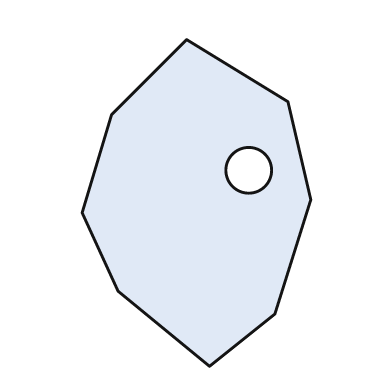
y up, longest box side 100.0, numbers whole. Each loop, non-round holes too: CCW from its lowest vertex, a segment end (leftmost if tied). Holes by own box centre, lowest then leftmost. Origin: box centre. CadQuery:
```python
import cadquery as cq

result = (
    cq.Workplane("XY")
    .moveTo(4.0, -50.0)
    .lineTo(24.0, -34.0)
    .lineTo(35.0, 1.0)
    .lineTo(28.0, 31.0)
    .lineTo(-3.0, 50.0)
    .lineTo(-26.0, 27.0)
    .lineTo(-35.0, -3.0)
    .lineTo(-24.0, -27.0)
    .close()
    .moveTo(16.0, 10.0)
    .circle(7.0)
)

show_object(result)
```